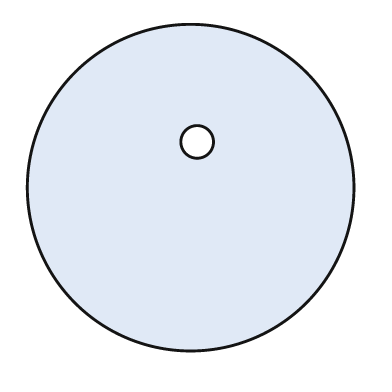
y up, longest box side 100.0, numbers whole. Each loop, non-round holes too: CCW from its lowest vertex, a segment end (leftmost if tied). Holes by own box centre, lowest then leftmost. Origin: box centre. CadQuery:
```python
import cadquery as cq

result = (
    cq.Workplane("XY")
    .moveTo(0.0, 0.0)
    .circle(50.0)
    .moveTo(2.0, 14.0)
    .circle(5.0)
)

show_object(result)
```